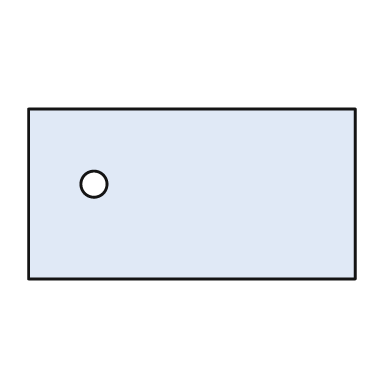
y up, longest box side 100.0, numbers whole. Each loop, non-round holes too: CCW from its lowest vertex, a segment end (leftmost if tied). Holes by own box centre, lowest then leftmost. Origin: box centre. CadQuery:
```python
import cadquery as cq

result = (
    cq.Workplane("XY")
    .moveTo(-50.0, -26.0)
    .lineTo(50.0, -26.0)
    .lineTo(50.0, 26.0)
    .lineTo(-50.0, 26.0)
    .close()
    .moveTo(-30.0, 3.0)
    .circle(4.0)
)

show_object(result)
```